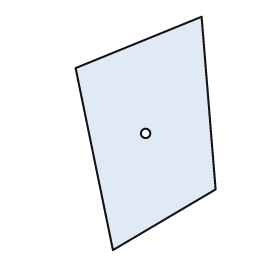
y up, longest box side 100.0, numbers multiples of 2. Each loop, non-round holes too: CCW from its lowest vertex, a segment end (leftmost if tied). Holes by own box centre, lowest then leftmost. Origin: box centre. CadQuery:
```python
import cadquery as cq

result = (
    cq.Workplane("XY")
    .moveTo(-14.0, -50.0)
    .lineTo(30.0, -24.0)
    .lineTo(24.0, 50.0)
    .lineTo(-30.0, 28.0)
    .close()
    .moveTo(0.0, 0.0)
    .circle(2.0)
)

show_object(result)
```